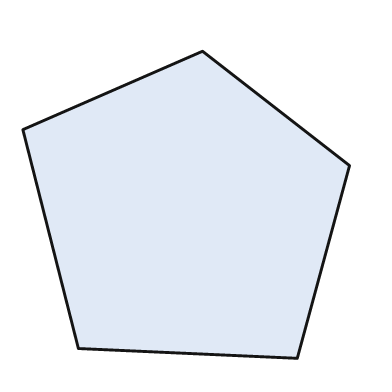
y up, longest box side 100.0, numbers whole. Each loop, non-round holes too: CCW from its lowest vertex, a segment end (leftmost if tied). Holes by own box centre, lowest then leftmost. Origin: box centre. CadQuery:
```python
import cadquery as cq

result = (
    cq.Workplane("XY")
    .moveTo(34.0, -47.0)
    .lineTo(50.0, 12.0)
    .lineTo(5.0, 47.0)
    .lineTo(-50.0, 23.0)
    .lineTo(-33.0, -44.0)
    .close()
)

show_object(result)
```